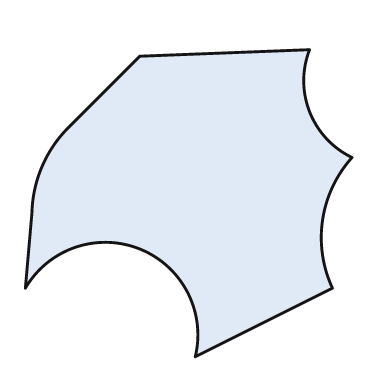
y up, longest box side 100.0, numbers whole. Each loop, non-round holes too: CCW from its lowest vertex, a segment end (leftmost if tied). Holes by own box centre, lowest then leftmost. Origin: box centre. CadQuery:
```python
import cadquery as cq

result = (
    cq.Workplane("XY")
    .moveTo(2.0, -47.0)
    .lineTo(44.0, -26.0)
    .threePointArc((41.0, -5.0), (50.0, 14.0))
    .threePointArc((37.0, 28.0), (37.0, 47.0))
    .lineTo(-15.0, 45.0)
    .lineTo(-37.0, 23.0)
    .threePointArc((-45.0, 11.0), (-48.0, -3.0))
    .lineTo(-50.0, -26.0)
    .threePointArc((-15.0, -14.0), (2.0, -47.0))
    .close()
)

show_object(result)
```